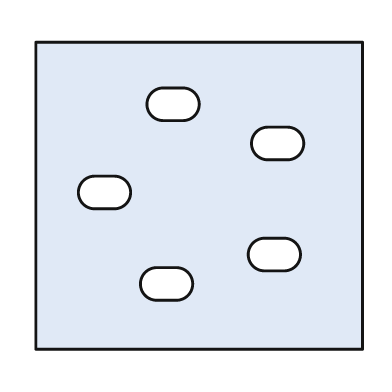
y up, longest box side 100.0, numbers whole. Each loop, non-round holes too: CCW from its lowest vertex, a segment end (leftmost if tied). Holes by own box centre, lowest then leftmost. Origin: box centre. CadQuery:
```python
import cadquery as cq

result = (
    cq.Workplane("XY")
    .moveTo(-50.0, -47.0)
    .lineTo(50.0, -47.0)
    .lineTo(50.0, 47.0)
    .lineTo(-50.0, 47.0)
    .close()
    .moveTo(-13.0, -32.0)
    .lineTo(-7.0, -32.0)
    .threePointArc((-2.0, -27.0), (-7.0, -22.0))
    .lineTo(-13.0, -22.0)
    .threePointArc((-18.0, -27.0), (-13.0, -32.0))
    .close()
    .moveTo(20.0, -23.0)
    .lineTo(26.0, -23.0)
    .threePointArc((31.0, -18.0), (26.0, -13.0))
    .lineTo(20.0, -13.0)
    .threePointArc((15.0, -18.0), (20.0, -23.0))
    .close()
    .moveTo(-32.0, -4.0)
    .lineTo(-26.0, -4.0)
    .threePointArc((-21.0, 1.0), (-26.0, 6.0))
    .lineTo(-32.0, 6.0)
    .threePointArc((-37.0, 1.0), (-32.0, -4.0))
    .close()
    .moveTo(21.0, 11.0)
    .lineTo(27.0, 11.0)
    .threePointArc((32.0, 16.0), (27.0, 21.0))
    .lineTo(21.0, 21.0)
    .threePointArc((16.0, 16.0), (21.0, 11.0))
    .close()
    .moveTo(-11.0, 23.0)
    .lineTo(-5.0, 23.0)
    .threePointArc((0.0, 28.0), (-5.0, 33.0))
    .lineTo(-11.0, 33.0)
    .threePointArc((-16.0, 28.0), (-11.0, 23.0))
    .close()
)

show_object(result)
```